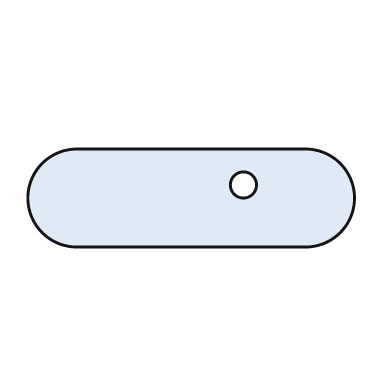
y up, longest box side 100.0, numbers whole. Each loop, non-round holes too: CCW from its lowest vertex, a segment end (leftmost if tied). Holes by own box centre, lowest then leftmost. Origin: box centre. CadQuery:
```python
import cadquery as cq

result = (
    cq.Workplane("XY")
    .moveTo(-35.0, -15.0)
    .lineTo(35.0, -15.0)
    .threePointArc((50.0, 0.0), (35.0, 15.0))
    .lineTo(-35.0, 15.0)
    .threePointArc((-50.0, 0.0), (-35.0, -15.0))
    .close()
    .moveTo(16.0, 4.0)
    .circle(4.0)
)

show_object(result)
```